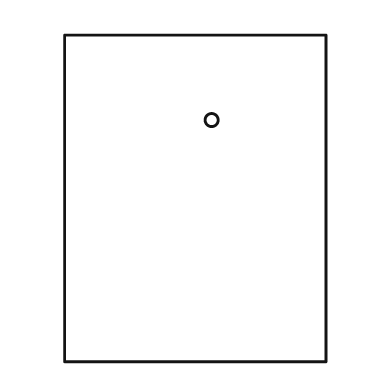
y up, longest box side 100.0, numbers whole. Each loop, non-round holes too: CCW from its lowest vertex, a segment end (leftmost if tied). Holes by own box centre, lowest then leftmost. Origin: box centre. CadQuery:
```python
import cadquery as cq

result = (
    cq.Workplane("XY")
    .moveTo(-40.0, -50.0)
    .lineTo(40.0, -50.0)
    .lineTo(40.0, 50.0)
    .lineTo(-40.0, 50.0)
    .close()
    .moveTo(5.0, 24.0)
    .circle(2.0)
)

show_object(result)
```